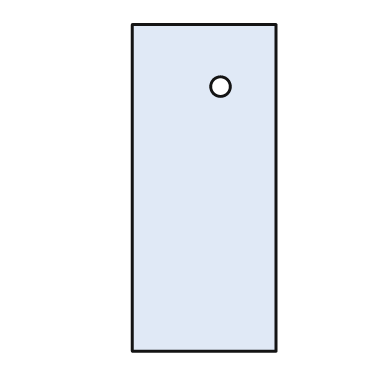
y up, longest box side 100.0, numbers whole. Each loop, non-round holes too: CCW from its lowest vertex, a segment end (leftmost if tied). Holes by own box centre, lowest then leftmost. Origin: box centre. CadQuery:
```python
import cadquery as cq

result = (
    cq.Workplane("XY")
    .moveTo(-22.0, -50.0)
    .lineTo(22.0, -50.0)
    .lineTo(22.0, 50.0)
    .lineTo(-22.0, 50.0)
    .close()
    .moveTo(5.0, 31.0)
    .circle(3.0)
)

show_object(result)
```